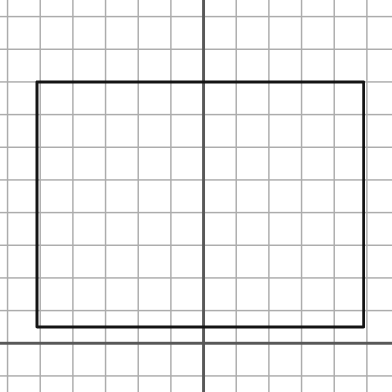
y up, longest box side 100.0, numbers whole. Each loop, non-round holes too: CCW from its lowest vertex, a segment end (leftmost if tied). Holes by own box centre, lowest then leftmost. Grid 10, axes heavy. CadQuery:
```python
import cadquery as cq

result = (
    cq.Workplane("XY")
    .moveTo(-51.0, 5.0)
    .lineTo(49.0, 5.0)
    .lineTo(49.0, 80.0)
    .lineTo(-51.0, 80.0)
    .close()
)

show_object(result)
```